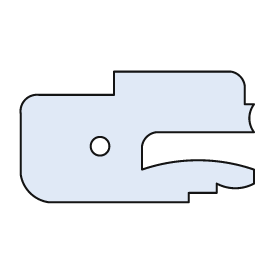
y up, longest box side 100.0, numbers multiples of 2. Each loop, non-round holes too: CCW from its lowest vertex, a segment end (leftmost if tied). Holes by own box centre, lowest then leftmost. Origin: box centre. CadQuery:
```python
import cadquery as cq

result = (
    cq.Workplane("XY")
    .moveTo(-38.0, -28.0)
    .lineTo(22.0, -28.0)
    .lineTo(22.0, -24.0)
    .lineTo(34.0, -24.0)
    .lineTo(34.0, -20.0)
    .threePointArc((42.0, -22.0), (50.0, -20.0))
    .lineTo(50.0, -14.0)
    .threePointArc((26.0, -10.0), (2.0, -14.0))
    .lineTo(2.0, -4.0)
    .threePointArc((4.0, 0.0), (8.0, 2.0))
    .lineTo(50.0, 2.0)
    .threePointArc((48.0, 8.0), (50.0, 14.0))
    .lineTo(46.0, 14.0)
    .lineTo(46.0, 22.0)
    .threePointArc((44.0, 26.0), (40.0, 28.0))
    .lineTo(-10.0, 28.0)
    .lineTo(-10.0, 18.0)
    .lineTo(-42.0, 18.0)
    .threePointArc((-48.0, 16.0), (-50.0, 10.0))
    .lineTo(-50.0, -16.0)
    .threePointArc((-46.0, -24.0), (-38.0, -28.0))
    .close()
    .moveTo(-16.0, -4.0)
    .circle(4.0)
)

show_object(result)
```